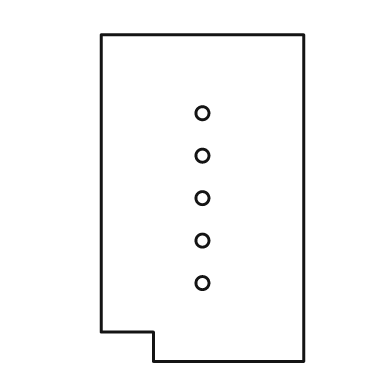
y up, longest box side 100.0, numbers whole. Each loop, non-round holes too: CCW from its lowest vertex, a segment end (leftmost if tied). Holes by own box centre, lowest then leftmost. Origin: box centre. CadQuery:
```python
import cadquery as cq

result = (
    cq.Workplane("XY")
    .moveTo(-15.0, -50.0)
    .lineTo(31.0, -50.0)
    .lineTo(31.0, 50.0)
    .lineTo(-31.0, 50.0)
    .lineTo(-31.0, -41.0)
    .lineTo(-15.0, -41.0)
    .close()
    .moveTo(0.0, -26.0)
    .circle(2.0)
    .moveTo(0.0, -13.0)
    .circle(2.0)
    .moveTo(0.0, 0.0)
    .circle(2.0)
    .moveTo(0.0, 13.0)
    .circle(2.0)
    .moveTo(0.0, 26.0)
    .circle(2.0)
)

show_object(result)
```